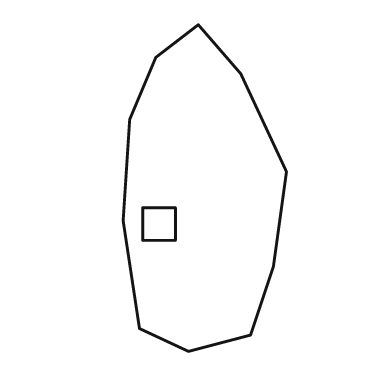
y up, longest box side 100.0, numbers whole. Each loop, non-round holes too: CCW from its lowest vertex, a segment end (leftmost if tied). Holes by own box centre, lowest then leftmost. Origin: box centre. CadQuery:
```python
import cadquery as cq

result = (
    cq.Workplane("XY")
    .moveTo(-5.0, -50.0)
    .lineTo(14.0, -45.0)
    .lineTo(21.0, -24.0)
    .lineTo(25.0, 5.0)
    .lineTo(11.0, 35.0)
    .lineTo(-2.0, 50.0)
    .lineTo(-15.0, 40.0)
    .lineTo(-23.0, 21.0)
    .lineTo(-25.0, -10.0)
    .lineTo(-20.0, -43.0)
    .close()
    .moveTo(-19.0, -16.0)
    .lineTo(-9.0, -16.0)
    .lineTo(-9.0, -6.0)
    .lineTo(-19.0, -6.0)
    .close()
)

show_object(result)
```